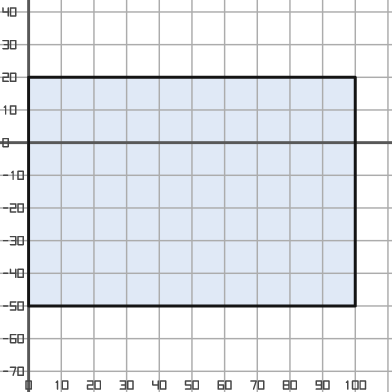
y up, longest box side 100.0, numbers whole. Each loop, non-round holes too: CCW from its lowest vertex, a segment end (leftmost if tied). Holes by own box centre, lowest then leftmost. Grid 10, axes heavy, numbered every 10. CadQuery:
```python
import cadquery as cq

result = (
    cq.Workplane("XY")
    .moveTo(0.0, -50.0)
    .lineTo(100.0, -50.0)
    .lineTo(100.0, 20.0)
    .lineTo(0.0, 20.0)
    .close()
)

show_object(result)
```